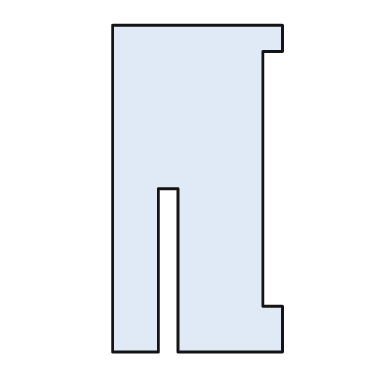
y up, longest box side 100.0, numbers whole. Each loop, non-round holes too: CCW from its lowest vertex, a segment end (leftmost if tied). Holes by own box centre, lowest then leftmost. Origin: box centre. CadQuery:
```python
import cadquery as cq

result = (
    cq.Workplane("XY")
    .moveTo(-26.0, -50.0)
    .lineTo(-12.0, -50.0)
    .lineTo(-12.0, 0.0)
    .lineTo(-6.0, 0.0)
    .lineTo(-6.0, -50.0)
    .lineTo(26.0, -50.0)
    .lineTo(26.0, -36.0)
    .lineTo(20.0, -36.0)
    .lineTo(20.0, 42.0)
    .lineTo(26.0, 42.0)
    .lineTo(26.0, 50.0)
    .lineTo(-26.0, 50.0)
    .close()
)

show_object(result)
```